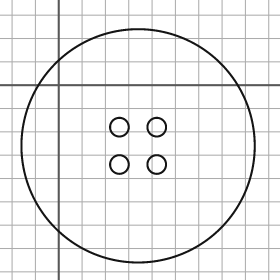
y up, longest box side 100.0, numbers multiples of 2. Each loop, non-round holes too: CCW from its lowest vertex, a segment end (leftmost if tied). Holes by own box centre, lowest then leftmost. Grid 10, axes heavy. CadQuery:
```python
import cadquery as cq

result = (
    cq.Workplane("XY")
    .moveTo(34.0, -26.0)
    .circle(50.0)
    .moveTo(26.0, -34.0)
    .circle(4.0)
    .moveTo(42.0, -34.0)
    .circle(4.0)
    .moveTo(26.0, -18.0)
    .circle(4.0)
    .moveTo(42.0, -18.0)
    .circle(4.0)
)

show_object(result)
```